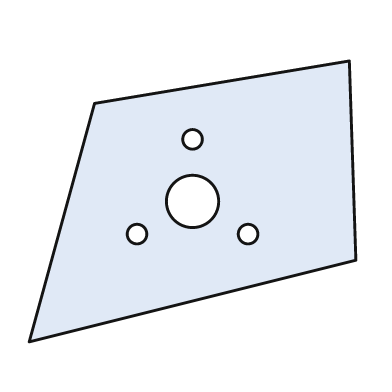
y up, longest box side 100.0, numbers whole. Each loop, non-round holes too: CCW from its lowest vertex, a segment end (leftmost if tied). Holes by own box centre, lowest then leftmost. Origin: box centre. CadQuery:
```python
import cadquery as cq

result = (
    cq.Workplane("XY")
    .moveTo(-50.0, -43.0)
    .lineTo(50.0, -18.0)
    .lineTo(48.0, 43.0)
    .lineTo(-30.0, 30.0)
    .close()
    .moveTo(-17.0, -10.0)
    .circle(3.0)
    .moveTo(17.0, -10.0)
    .circle(3.0)
    .moveTo(0.0, 0.0)
    .circle(8.0)
    .moveTo(0.0, 19.0)
    .circle(3.0)
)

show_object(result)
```